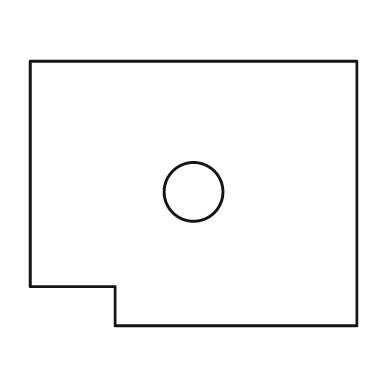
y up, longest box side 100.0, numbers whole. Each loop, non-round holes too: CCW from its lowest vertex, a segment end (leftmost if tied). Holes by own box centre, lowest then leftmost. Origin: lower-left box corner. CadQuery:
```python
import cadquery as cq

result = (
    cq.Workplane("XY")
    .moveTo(26.0, 0.0)
    .lineTo(100.0, 0.0)
    .lineTo(100.0, 81.0)
    .lineTo(0.0, 81.0)
    .lineTo(0.0, 12.0)
    .lineTo(26.0, 12.0)
    .close()
    .moveTo(50.0, 41.0)
    .circle(9.0)
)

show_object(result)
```